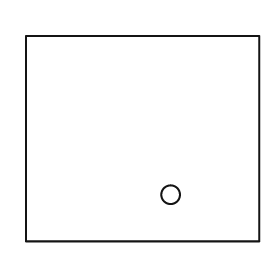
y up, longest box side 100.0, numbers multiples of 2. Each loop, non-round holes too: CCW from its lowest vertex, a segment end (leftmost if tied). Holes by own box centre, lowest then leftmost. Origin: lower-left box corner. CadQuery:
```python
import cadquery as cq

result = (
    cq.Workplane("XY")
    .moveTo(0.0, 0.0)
    .lineTo(100.0, 0.0)
    .lineTo(100.0, 88.0)
    .lineTo(0.0, 88.0)
    .close()
    .moveTo(62.0, 20.0)
    .circle(4.0)
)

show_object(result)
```